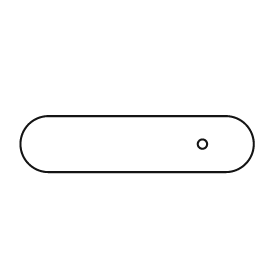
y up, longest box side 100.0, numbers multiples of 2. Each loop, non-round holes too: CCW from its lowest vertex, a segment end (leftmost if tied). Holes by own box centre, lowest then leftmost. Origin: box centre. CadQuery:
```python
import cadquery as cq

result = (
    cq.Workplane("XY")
    .moveTo(-38.0, -12.0)
    .lineTo(38.0, -12.0)
    .threePointArc((50.0, 0.0), (38.0, 12.0))
    .lineTo(-38.0, 12.0)
    .threePointArc((-50.0, 0.0), (-38.0, -12.0))
    .close()
    .moveTo(28.0, 0.0)
    .circle(2.0)
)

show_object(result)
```